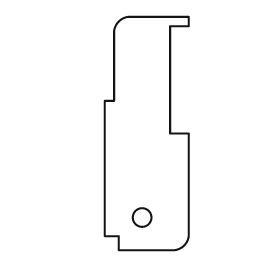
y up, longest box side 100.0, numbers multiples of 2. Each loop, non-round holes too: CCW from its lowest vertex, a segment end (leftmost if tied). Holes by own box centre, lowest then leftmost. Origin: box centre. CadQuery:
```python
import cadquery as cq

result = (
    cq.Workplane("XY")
    .moveTo(-12.0, -50.0)
    .lineTo(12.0, -50.0)
    .threePointArc((16.0, -48.0), (18.0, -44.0))
    .lineTo(18.0, 0.0)
    .lineTo(10.0, 0.0)
    .lineTo(10.0, 46.0)
    .lineTo(18.0, 46.0)
    .lineTo(18.0, 50.0)
    .lineTo(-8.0, 50.0)
    .threePointArc((-12.0, 48.0), (-14.0, 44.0))
    .lineTo(-14.0, 14.0)
    .lineTo(-18.0, 14.0)
    .lineTo(-18.0, -44.0)
    .lineTo(-12.0, -44.0)
    .close()
    .moveTo(-2.0, -36.0)
    .circle(4.0)
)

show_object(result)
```